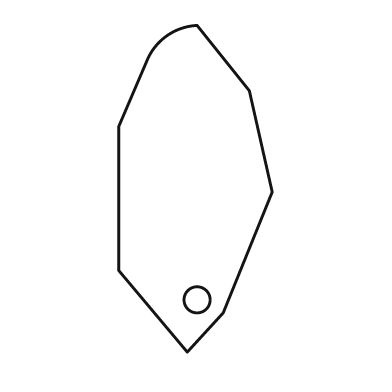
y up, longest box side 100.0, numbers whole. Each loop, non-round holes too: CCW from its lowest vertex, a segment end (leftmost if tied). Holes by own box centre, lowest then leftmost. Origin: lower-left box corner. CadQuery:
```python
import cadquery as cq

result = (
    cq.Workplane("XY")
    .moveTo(21.0, 0.0)
    .lineTo(32.0, 12.0)
    .lineTo(47.0, 49.0)
    .lineTo(40.0, 80.0)
    .lineTo(24.0, 100.0)
    .threePointArc((15.0, 97.0), (9.0, 90.0))
    .lineTo(0.0, 69.0)
    .lineTo(0.0, 25.0)
    .close()
    .moveTo(24.0, 16.0)
    .circle(4.0)
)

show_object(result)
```